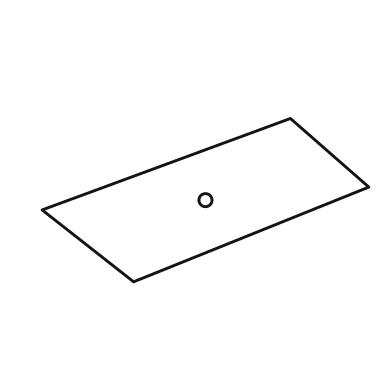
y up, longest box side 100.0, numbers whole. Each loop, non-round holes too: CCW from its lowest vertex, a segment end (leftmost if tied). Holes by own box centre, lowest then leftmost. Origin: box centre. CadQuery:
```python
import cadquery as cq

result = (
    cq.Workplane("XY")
    .moveTo(-22.0, -25.0)
    .lineTo(50.0, 4.0)
    .lineTo(26.0, 25.0)
    .lineTo(-50.0, -3.0)
    .close()
    .moveTo(0.0, 0.0)
    .circle(2.0)
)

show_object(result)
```